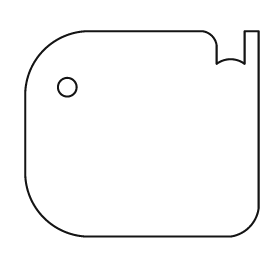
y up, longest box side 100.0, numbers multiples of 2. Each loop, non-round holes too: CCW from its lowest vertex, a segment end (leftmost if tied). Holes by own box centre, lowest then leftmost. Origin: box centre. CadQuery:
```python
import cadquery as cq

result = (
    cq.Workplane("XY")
    .moveTo(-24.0, -44.0)
    .lineTo(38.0, -44.0)
    .threePointArc((46.0, -40.0), (50.0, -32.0))
    .lineTo(50.0, 44.0)
    .lineTo(44.0, 44.0)
    .lineTo(44.0, 30.0)
    .threePointArc((38.0, 32.0), (32.0, 30.0))
    .lineTo(32.0, 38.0)
    .threePointArc((30.0, 42.0), (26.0, 44.0))
    .lineTo(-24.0, 44.0)
    .threePointArc((-42.0, 36.0), (-50.0, 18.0))
    .lineTo(-50.0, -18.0)
    .threePointArc((-42.0, -36.0), (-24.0, -44.0))
    .close()
    .moveTo(-32.0, 20.0)
    .circle(4.0)
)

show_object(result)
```